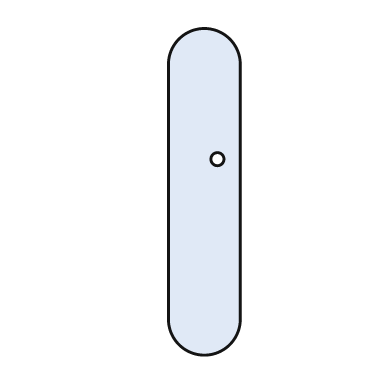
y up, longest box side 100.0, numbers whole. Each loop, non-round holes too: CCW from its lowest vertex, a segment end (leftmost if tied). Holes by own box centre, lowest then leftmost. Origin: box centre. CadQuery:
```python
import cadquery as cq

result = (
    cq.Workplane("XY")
    .moveTo(-11.0, -39.0)
    .threePointArc((0.0, -50.0), (11.0, -39.0))
    .lineTo(11.0, 39.0)
    .threePointArc((0.0, 50.0), (-11.0, 39.0))
    .close()
    .moveTo(4.0, 10.0)
    .circle(2.0)
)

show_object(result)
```